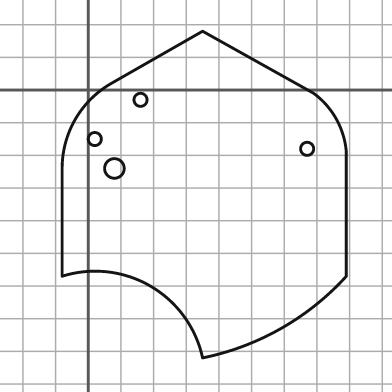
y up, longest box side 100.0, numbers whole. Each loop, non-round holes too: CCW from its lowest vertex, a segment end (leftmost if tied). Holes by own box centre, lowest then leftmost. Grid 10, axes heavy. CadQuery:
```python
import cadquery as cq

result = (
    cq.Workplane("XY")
    .moveTo(35.0, -82.0)
    .threePointArc((59.0, -73.0), (79.0, -57.0))
    .lineTo(79.0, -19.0)
    .threePointArc((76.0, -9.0), (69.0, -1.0))
    .lineTo(35.0, 18.0)
    .lineTo(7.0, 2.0)
    .threePointArc((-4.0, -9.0), (-8.0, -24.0))
    .lineTo(-8.0, -57.0)
    .threePointArc((19.0, -60.0), (35.0, -82.0))
    .close()
    .moveTo(8.0, -24.0)
    .circle(3.0)
    .moveTo(67.0, -18.0)
    .circle(2.0)
    .moveTo(2.0, -15.0)
    .circle(2.0)
    .moveTo(16.0, -3.0)
    .circle(2.0)
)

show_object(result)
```